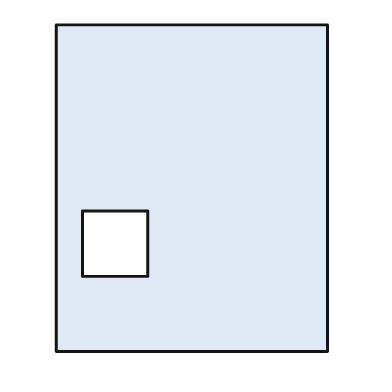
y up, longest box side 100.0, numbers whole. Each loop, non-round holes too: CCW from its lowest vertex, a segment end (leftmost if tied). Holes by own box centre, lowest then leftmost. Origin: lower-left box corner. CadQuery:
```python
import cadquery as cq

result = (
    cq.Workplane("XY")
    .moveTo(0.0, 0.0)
    .lineTo(83.0, 0.0)
    .lineTo(83.0, 100.0)
    .lineTo(0.0, 100.0)
    .close()
    .moveTo(8.0, 23.0)
    .lineTo(28.0, 23.0)
    .lineTo(28.0, 43.0)
    .lineTo(8.0, 43.0)
    .close()
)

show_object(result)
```